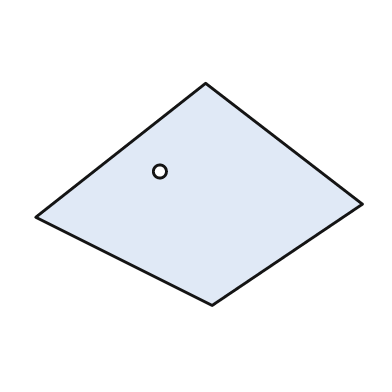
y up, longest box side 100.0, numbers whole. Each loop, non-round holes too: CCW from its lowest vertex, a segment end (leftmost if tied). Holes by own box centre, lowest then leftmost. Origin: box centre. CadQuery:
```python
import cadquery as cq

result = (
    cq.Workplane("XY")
    .moveTo(4.0, -34.0)
    .lineTo(50.0, -3.0)
    .lineTo(2.0, 34.0)
    .lineTo(-50.0, -7.0)
    .close()
    .moveTo(-12.0, 7.0)
    .circle(2.0)
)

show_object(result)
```